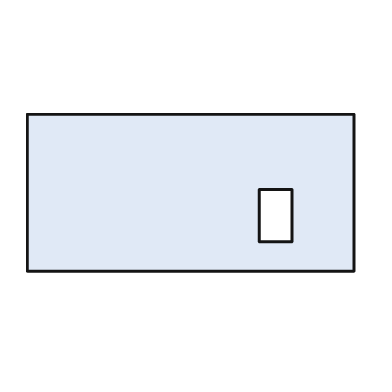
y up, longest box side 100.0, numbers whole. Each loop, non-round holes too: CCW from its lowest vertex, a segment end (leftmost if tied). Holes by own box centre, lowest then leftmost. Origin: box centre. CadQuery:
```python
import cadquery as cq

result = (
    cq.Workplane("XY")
    .moveTo(-50.0, -24.0)
    .lineTo(50.0, -24.0)
    .lineTo(50.0, 24.0)
    .lineTo(-50.0, 24.0)
    .close()
    .moveTo(21.0, -15.0)
    .lineTo(31.0, -15.0)
    .lineTo(31.0, 1.0)
    .lineTo(21.0, 1.0)
    .close()
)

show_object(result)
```